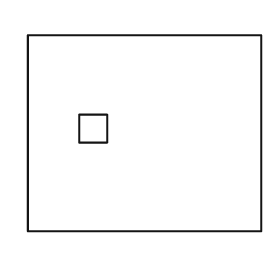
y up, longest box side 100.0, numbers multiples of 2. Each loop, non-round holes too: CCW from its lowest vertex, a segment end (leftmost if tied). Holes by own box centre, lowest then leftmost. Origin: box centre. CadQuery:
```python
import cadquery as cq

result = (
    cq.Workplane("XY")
    .moveTo(-50.0, -42.0)
    .lineTo(50.0, -42.0)
    .lineTo(50.0, 42.0)
    .lineTo(-50.0, 42.0)
    .close()
    .moveTo(-28.0, -4.0)
    .lineTo(-16.0, -4.0)
    .lineTo(-16.0, 8.0)
    .lineTo(-28.0, 8.0)
    .close()
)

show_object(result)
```